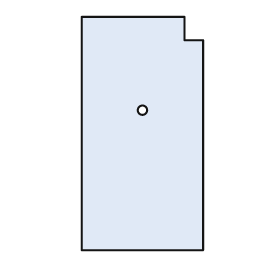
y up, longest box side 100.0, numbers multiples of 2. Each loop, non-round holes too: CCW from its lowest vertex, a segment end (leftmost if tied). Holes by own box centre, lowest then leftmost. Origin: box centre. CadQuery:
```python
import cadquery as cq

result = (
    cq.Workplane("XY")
    .moveTo(-26.0, -50.0)
    .lineTo(26.0, -50.0)
    .lineTo(26.0, 40.0)
    .lineTo(18.0, 40.0)
    .lineTo(18.0, 50.0)
    .lineTo(-26.0, 50.0)
    .close()
    .moveTo(0.0, 10.0)
    .circle(2.0)
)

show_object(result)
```